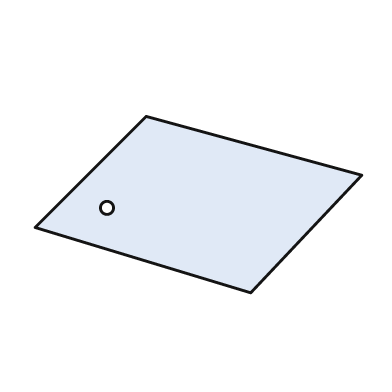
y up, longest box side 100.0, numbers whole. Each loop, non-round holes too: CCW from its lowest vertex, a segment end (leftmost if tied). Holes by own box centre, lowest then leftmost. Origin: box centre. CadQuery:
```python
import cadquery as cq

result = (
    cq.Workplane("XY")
    .moveTo(16.0, -27.0)
    .lineTo(50.0, 9.0)
    .lineTo(-16.0, 27.0)
    .lineTo(-50.0, -7.0)
    .close()
    .moveTo(-28.0, -1.0)
    .circle(2.0)
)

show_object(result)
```